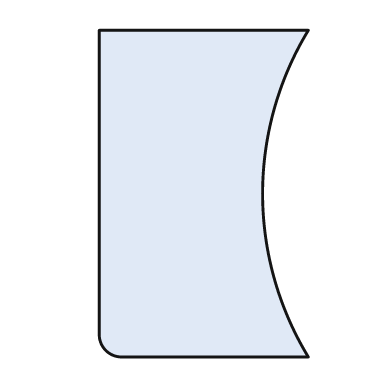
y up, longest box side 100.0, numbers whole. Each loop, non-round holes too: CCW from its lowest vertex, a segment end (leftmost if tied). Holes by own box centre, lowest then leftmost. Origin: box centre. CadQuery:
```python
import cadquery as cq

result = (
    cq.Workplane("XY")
    .moveTo(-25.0, -50.0)
    .lineTo(32.0, -50.0)
    .threePointArc((18.0, 0.0), (32.0, 50.0))
    .lineTo(-32.0, 50.0)
    .lineTo(-32.0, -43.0)
    .threePointArc((-30.0, -48.0), (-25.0, -50.0))
    .close()
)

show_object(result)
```